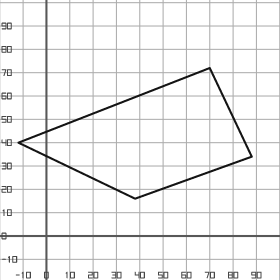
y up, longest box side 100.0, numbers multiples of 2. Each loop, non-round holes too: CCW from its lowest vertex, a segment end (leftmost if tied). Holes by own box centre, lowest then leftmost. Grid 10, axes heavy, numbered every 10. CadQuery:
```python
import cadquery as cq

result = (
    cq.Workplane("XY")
    .moveTo(38.0, 16.0)
    .lineTo(88.0, 34.0)
    .lineTo(70.0, 72.0)
    .lineTo(-12.0, 40.0)
    .close()
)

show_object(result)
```